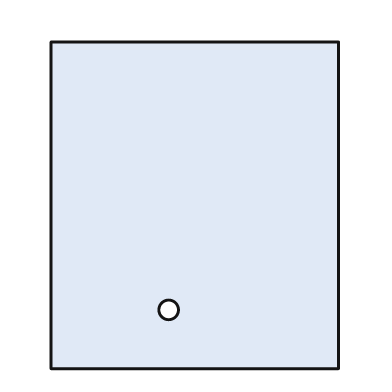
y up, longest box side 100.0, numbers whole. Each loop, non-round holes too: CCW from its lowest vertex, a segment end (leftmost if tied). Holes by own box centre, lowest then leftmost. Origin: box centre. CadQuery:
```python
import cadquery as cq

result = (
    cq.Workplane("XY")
    .moveTo(-44.0, -50.0)
    .lineTo(44.0, -50.0)
    .lineTo(44.0, 50.0)
    .lineTo(-44.0, 50.0)
    .close()
    .moveTo(-8.0, -32.0)
    .circle(3.0)
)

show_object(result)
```